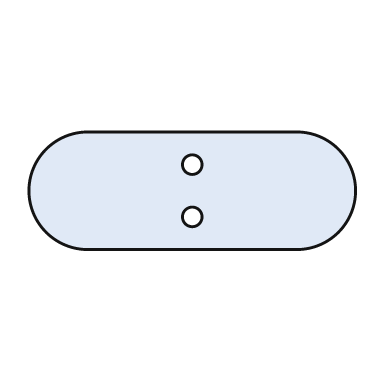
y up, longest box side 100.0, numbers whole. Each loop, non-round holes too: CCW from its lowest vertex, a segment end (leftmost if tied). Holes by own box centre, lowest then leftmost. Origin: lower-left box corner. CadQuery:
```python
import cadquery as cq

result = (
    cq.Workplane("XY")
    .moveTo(18.0, 0.0)
    .lineTo(82.0, 0.0)
    .threePointArc((100.0, 18.0), (82.0, 36.0))
    .lineTo(18.0, 36.0)
    .threePointArc((0.0, 18.0), (18.0, 0.0))
    .close()
    .moveTo(50.0, 10.0)
    .circle(3.0)
    .moveTo(50.0, 26.0)
    .circle(3.0)
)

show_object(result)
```